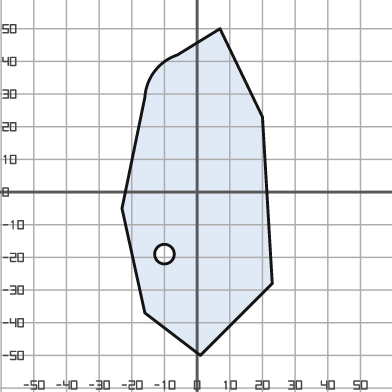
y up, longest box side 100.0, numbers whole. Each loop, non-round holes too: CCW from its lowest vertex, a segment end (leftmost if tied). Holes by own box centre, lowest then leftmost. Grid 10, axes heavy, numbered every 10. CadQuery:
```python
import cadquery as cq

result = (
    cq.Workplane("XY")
    .moveTo(1.0, -50.0)
    .lineTo(23.0, -28.0)
    .lineTo(20.0, 23.0)
    .lineTo(7.0, 50.0)
    .lineTo(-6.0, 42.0)
    .threePointArc((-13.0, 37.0), (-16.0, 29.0))
    .lineTo(-23.0, -5.0)
    .lineTo(-16.0, -37.0)
    .close()
    .moveTo(-10.0, -19.0)
    .circle(3.0)
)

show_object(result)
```